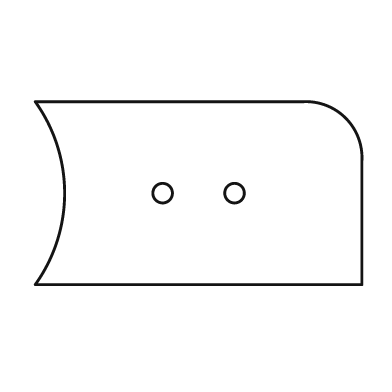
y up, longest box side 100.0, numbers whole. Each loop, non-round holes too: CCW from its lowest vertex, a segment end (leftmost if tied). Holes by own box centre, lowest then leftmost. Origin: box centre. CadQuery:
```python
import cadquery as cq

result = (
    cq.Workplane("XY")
    .moveTo(-50.0, -28.0)
    .lineTo(50.0, -28.0)
    .lineTo(50.0, 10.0)
    .threePointArc((45.0, 23.0), (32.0, 28.0))
    .lineTo(-50.0, 28.0)
    .threePointArc((-41.0, 0.0), (-50.0, -28.0))
    .close()
    .moveTo(-11.0, 0.0)
    .circle(3.0)
    .moveTo(11.0, 0.0)
    .circle(3.0)
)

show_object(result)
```